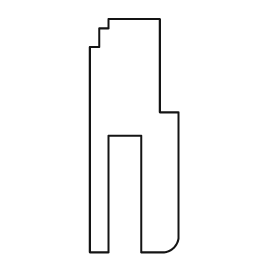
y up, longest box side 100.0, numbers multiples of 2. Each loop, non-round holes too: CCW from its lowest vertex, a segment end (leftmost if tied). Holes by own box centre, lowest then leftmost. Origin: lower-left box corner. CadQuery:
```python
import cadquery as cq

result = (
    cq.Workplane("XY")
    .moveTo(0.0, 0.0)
    .lineTo(8.0, 0.0)
    .lineTo(8.0, 50.0)
    .lineTo(22.0, 50.0)
    .lineTo(22.0, 0.0)
    .lineTo(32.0, 0.0)
    .threePointArc((36.0, 2.0), (38.0, 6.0))
    .lineTo(38.0, 60.0)
    .lineTo(30.0, 60.0)
    .lineTo(30.0, 100.0)
    .lineTo(8.0, 100.0)
    .lineTo(8.0, 96.0)
    .lineTo(4.0, 96.0)
    .lineTo(4.0, 88.0)
    .lineTo(0.0, 88.0)
    .close()
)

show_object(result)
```